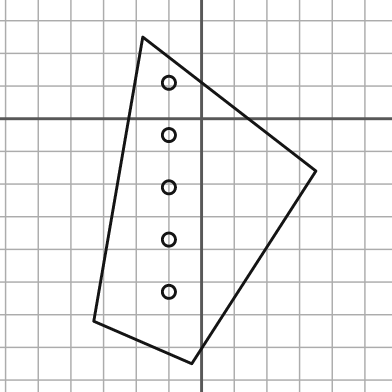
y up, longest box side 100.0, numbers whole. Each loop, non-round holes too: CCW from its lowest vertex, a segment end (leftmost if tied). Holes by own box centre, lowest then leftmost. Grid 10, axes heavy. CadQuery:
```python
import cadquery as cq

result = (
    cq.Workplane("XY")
    .moveTo(-3.0, -75.0)
    .lineTo(35.0, -16.0)
    .lineTo(-18.0, 25.0)
    .lineTo(-33.0, -62.0)
    .close()
    .moveTo(-10.0, -53.0)
    .circle(2.0)
    .moveTo(-10.0, -37.0)
    .circle(2.0)
    .moveTo(-10.0, -21.0)
    .circle(2.0)
    .moveTo(-10.0, -5.0)
    .circle(2.0)
    .moveTo(-10.0, 11.0)
    .circle(2.0)
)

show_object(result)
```